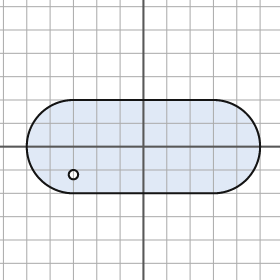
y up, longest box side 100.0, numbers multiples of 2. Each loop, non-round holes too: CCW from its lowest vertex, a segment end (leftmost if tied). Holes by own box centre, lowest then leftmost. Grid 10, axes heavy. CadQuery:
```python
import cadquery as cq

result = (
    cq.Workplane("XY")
    .moveTo(-30.0, -20.0)
    .lineTo(30.0, -20.0)
    .threePointArc((50.0, 0.0), (30.0, 20.0))
    .lineTo(-30.0, 20.0)
    .threePointArc((-50.0, 0.0), (-30.0, -20.0))
    .close()
    .moveTo(-30.0, -12.0)
    .circle(2.0)
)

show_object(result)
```